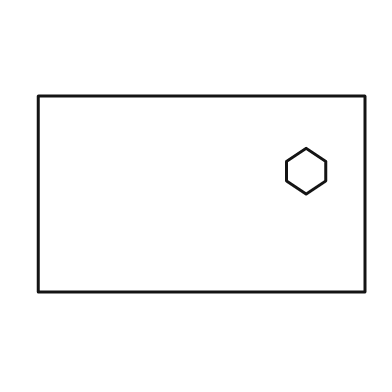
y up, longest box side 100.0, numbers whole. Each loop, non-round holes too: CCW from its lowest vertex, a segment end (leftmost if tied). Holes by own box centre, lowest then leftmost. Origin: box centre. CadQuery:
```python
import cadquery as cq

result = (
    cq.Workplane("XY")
    .moveTo(-50.0, -30.0)
    .lineTo(50.0, -30.0)
    .lineTo(50.0, 30.0)
    .lineTo(-50.0, 30.0)
    .close()
    .moveTo(32.0, 0.0)
    .lineTo(38.0, 4.0)
    .lineTo(38.0, 10.0)
    .lineTo(32.0, 14.0)
    .lineTo(26.0, 10.0)
    .lineTo(26.0, 4.0)
    .close()
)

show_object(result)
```